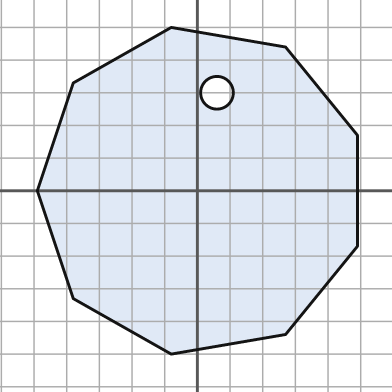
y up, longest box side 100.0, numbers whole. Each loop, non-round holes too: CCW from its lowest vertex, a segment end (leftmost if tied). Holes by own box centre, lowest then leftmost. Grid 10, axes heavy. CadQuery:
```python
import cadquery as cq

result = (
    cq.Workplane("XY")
    .moveTo(-8.0, -50.0)
    .lineTo(27.0, -44.0)
    .lineTo(49.0, -17.0)
    .lineTo(49.0, 17.0)
    .lineTo(27.0, 44.0)
    .lineTo(-8.0, 50.0)
    .lineTo(-38.0, 33.0)
    .lineTo(-49.0, 0.0)
    .lineTo(-38.0, -33.0)
    .close()
    .moveTo(6.0, 30.0)
    .circle(5.0)
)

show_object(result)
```